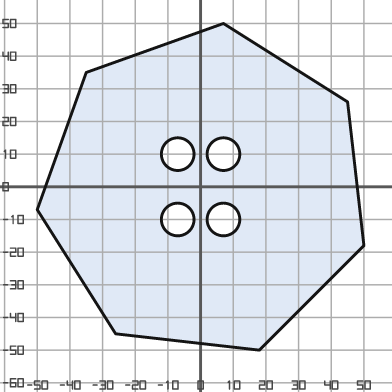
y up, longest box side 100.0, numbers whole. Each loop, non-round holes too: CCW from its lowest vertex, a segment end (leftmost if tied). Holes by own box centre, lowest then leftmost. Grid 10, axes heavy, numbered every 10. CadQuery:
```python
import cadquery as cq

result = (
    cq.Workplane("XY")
    .moveTo(18.0, -50.0)
    .lineTo(50.0, -18.0)
    .lineTo(45.0, 26.0)
    .lineTo(7.0, 50.0)
    .lineTo(-35.0, 35.0)
    .lineTo(-50.0, -7.0)
    .lineTo(-26.0, -45.0)
    .close()
    .moveTo(-7.0, -10.0)
    .circle(5.0)
    .moveTo(7.0, -10.0)
    .circle(5.0)
    .moveTo(-7.0, 10.0)
    .circle(5.0)
    .moveTo(7.0, 10.0)
    .circle(5.0)
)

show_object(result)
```